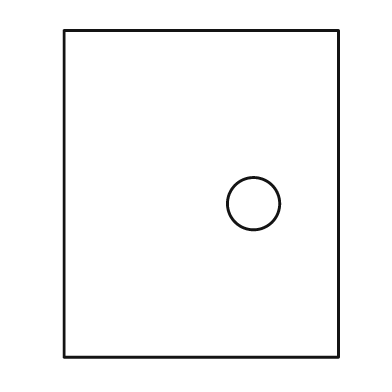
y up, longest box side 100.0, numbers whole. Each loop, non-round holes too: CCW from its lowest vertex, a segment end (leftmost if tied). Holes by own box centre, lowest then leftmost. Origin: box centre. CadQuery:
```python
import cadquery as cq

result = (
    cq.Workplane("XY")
    .moveTo(-42.0, -50.0)
    .lineTo(42.0, -50.0)
    .lineTo(42.0, 50.0)
    .lineTo(-42.0, 50.0)
    .close()
    .moveTo(16.0, -3.0)
    .circle(8.0)
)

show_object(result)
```